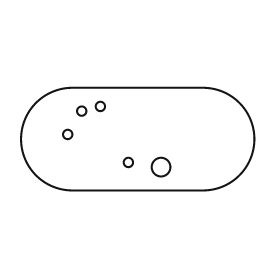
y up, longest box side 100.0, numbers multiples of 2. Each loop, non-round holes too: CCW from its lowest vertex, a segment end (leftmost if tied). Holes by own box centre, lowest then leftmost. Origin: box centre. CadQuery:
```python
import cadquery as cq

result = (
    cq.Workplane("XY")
    .moveTo(-28.0, -22.0)
    .lineTo(28.0, -22.0)
    .threePointArc((50.0, 0.0), (28.0, 22.0))
    .lineTo(-28.0, 22.0)
    .threePointArc((-50.0, 0.0), (-28.0, -22.0))
    .close()
    .moveTo(10.0, -12.0)
    .circle(4.0)
    .moveTo(-4.0, -10.0)
    .circle(2.0)
    .moveTo(-30.0, 2.0)
    .circle(2.0)
    .moveTo(-24.0, 12.0)
    .circle(2.0)
    .moveTo(-16.0, 14.0)
    .circle(2.0)
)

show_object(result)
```